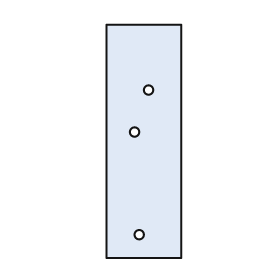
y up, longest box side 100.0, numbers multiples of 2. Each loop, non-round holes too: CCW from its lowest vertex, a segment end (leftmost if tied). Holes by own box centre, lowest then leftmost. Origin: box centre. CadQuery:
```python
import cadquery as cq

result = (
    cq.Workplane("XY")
    .moveTo(-16.0, -50.0)
    .lineTo(16.0, -50.0)
    .lineTo(16.0, 50.0)
    .lineTo(-16.0, 50.0)
    .close()
    .moveTo(-2.0, -40.0)
    .circle(2.0)
    .moveTo(-4.0, 4.0)
    .circle(2.0)
    .moveTo(2.0, 22.0)
    .circle(2.0)
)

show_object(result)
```